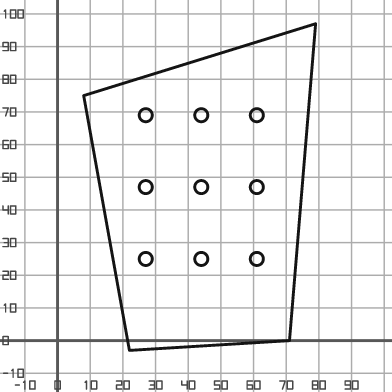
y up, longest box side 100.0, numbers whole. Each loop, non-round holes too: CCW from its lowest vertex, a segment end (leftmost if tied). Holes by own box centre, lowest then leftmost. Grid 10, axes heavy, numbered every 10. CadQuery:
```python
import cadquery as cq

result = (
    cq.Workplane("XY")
    .moveTo(22.0, -3.0)
    .lineTo(71.0, 0.0)
    .lineTo(79.0, 97.0)
    .lineTo(8.0, 75.0)
    .close()
    .moveTo(27.0, 25.0)
    .circle(2.0)
    .moveTo(44.0, 25.0)
    .circle(2.0)
    .moveTo(61.0, 25.0)
    .circle(2.0)
    .moveTo(27.0, 47.0)
    .circle(2.0)
    .moveTo(44.0, 47.0)
    .circle(2.0)
    .moveTo(61.0, 47.0)
    .circle(2.0)
    .moveTo(27.0, 69.0)
    .circle(2.0)
    .moveTo(44.0, 69.0)
    .circle(2.0)
    .moveTo(61.0, 69.0)
    .circle(2.0)
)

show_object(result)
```